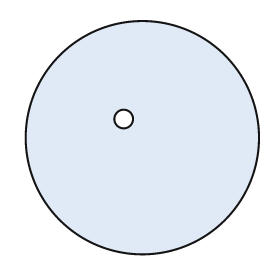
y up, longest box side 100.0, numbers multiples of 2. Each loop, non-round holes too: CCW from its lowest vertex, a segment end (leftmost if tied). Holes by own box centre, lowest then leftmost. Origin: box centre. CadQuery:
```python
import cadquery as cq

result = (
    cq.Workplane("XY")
    .moveTo(0.0, 0.0)
    .circle(50.0)
    .moveTo(-8.0, 8.0)
    .circle(4.0)
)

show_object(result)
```